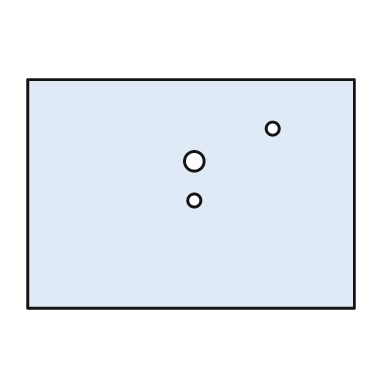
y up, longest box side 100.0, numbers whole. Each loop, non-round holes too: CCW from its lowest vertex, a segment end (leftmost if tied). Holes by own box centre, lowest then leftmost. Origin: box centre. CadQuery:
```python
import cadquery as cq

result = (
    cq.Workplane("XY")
    .moveTo(-50.0, -35.0)
    .lineTo(50.0, -35.0)
    .lineTo(50.0, 35.0)
    .lineTo(-50.0, 35.0)
    .close()
    .moveTo(1.0, -2.0)
    .circle(2.0)
    .moveTo(1.0, 10.0)
    .circle(3.0)
    .moveTo(25.0, 20.0)
    .circle(2.0)
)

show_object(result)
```